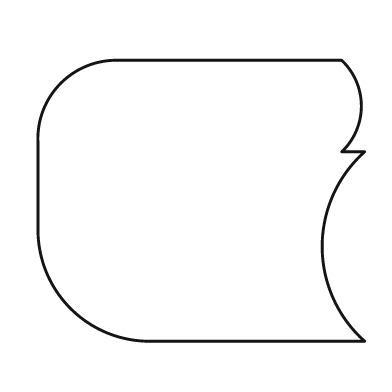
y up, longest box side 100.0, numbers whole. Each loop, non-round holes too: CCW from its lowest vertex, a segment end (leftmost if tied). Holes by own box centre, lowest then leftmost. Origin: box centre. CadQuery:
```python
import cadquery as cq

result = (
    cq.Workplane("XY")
    .moveTo(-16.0, -43.0)
    .lineTo(50.0, -43.0)
    .threePointArc((37.0, -14.0), (50.0, 15.0))
    .lineTo(43.0, 15.0)
    .threePointArc((49.0, 29.0), (43.0, 43.0))
    .lineTo(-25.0, 43.0)
    .threePointArc((-43.0, 36.0), (-50.0, 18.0))
    .lineTo(-50.0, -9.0)
    .threePointArc((-40.0, -33.0), (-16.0, -43.0))
    .close()
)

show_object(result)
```